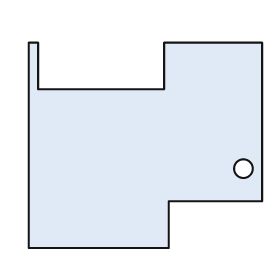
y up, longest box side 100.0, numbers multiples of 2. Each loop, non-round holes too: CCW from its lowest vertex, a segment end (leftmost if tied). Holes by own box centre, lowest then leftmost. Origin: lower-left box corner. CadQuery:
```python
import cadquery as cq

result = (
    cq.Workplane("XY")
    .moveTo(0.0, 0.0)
    .lineTo(60.0, 0.0)
    .lineTo(60.0, 20.0)
    .lineTo(100.0, 20.0)
    .lineTo(100.0, 88.0)
    .lineTo(58.0, 88.0)
    .lineTo(58.0, 68.0)
    .lineTo(4.0, 68.0)
    .lineTo(4.0, 88.0)
    .lineTo(0.0, 88.0)
    .close()
    .moveTo(92.0, 34.0)
    .circle(4.0)
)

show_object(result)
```